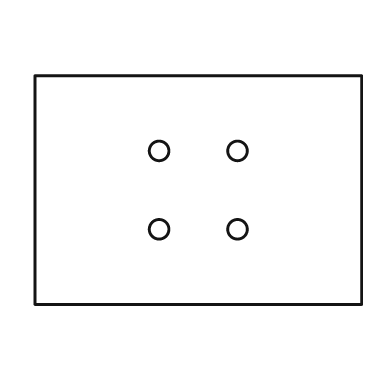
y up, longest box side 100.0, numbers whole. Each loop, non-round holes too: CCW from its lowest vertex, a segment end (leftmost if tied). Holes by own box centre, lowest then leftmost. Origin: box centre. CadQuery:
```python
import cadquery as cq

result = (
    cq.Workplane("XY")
    .moveTo(-50.0, -35.0)
    .lineTo(50.0, -35.0)
    .lineTo(50.0, 35.0)
    .lineTo(-50.0, 35.0)
    .close()
    .moveTo(-12.0, -12.0)
    .circle(3.0)
    .moveTo(12.0, -12.0)
    .circle(3.0)
    .moveTo(-12.0, 12.0)
    .circle(3.0)
    .moveTo(12.0, 12.0)
    .circle(3.0)
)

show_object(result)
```